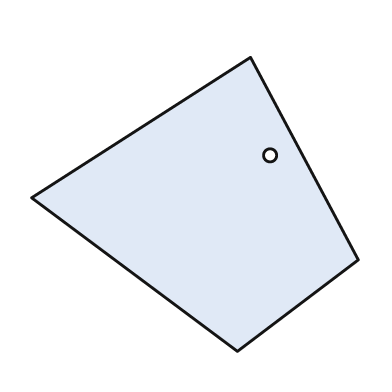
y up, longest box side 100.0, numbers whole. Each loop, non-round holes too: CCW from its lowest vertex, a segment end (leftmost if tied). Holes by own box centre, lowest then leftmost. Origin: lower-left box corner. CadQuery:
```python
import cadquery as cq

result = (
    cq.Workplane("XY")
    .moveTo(63.0, 0.0)
    .lineTo(100.0, 28.0)
    .lineTo(67.0, 90.0)
    .lineTo(0.0, 47.0)
    .close()
    .moveTo(73.0, 60.0)
    .circle(2.0)
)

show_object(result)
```